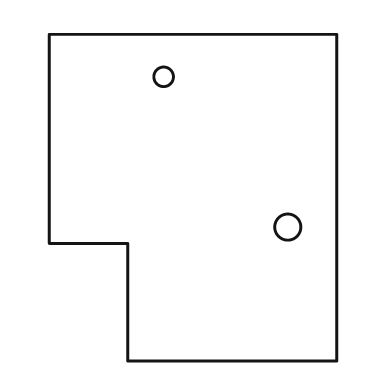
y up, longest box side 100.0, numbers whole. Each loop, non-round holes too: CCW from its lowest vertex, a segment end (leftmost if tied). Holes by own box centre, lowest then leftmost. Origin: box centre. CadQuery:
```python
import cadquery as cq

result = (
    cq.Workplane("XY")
    .moveTo(-20.0, -50.0)
    .lineTo(44.0, -50.0)
    .lineTo(44.0, 50.0)
    .lineTo(-44.0, 50.0)
    .lineTo(-44.0, -14.0)
    .lineTo(-20.0, -14.0)
    .close()
    .moveTo(29.0, -9.0)
    .circle(4.0)
    .moveTo(-9.0, 37.0)
    .circle(3.0)
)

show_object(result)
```